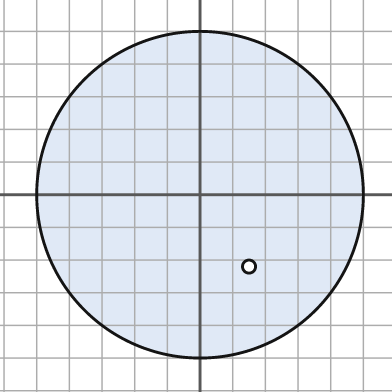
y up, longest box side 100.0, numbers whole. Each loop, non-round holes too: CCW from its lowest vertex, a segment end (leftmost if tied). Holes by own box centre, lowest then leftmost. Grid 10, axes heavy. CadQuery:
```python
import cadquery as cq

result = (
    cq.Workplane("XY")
    .moveTo(0.0, 0.0)
    .circle(50.0)
    .moveTo(15.0, -22.0)
    .circle(2.0)
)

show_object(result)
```